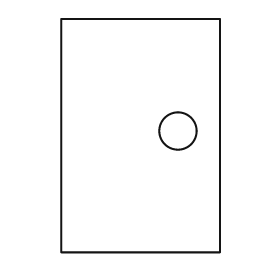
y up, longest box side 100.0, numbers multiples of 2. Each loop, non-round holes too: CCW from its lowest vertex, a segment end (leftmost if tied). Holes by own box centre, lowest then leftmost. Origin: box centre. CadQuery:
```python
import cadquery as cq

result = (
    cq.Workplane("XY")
    .moveTo(-34.0, -50.0)
    .lineTo(34.0, -50.0)
    .lineTo(34.0, 50.0)
    .lineTo(-34.0, 50.0)
    .close()
    .moveTo(16.0, 2.0)
    .circle(8.0)
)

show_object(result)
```